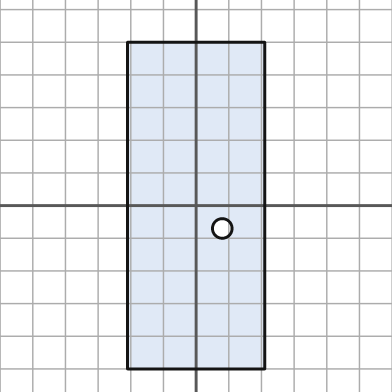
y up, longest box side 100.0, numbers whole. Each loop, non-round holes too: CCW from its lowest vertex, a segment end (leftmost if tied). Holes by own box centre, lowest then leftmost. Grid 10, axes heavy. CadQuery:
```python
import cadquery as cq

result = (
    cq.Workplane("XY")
    .moveTo(-21.0, -50.0)
    .lineTo(21.0, -50.0)
    .lineTo(21.0, 50.0)
    .lineTo(-21.0, 50.0)
    .close()
    .moveTo(8.0, -7.0)
    .circle(3.0)
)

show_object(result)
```